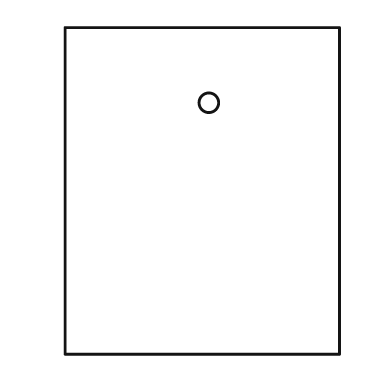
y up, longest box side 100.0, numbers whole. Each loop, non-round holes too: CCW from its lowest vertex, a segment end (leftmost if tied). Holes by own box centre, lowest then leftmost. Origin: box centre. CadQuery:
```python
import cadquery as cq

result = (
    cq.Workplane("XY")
    .moveTo(-42.0, -50.0)
    .lineTo(42.0, -50.0)
    .lineTo(42.0, 50.0)
    .lineTo(-42.0, 50.0)
    .close()
    .moveTo(2.0, 27.0)
    .circle(3.0)
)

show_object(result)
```